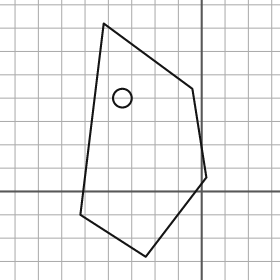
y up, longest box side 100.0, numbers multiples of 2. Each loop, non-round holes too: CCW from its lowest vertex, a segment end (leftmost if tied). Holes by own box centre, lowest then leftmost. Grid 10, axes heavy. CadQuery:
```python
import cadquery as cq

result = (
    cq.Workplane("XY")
    .moveTo(-24.0, -28.0)
    .lineTo(2.0, 6.0)
    .lineTo(-4.0, 44.0)
    .lineTo(-42.0, 72.0)
    .lineTo(-52.0, -10.0)
    .close()
    .moveTo(-34.0, 40.0)
    .circle(4.0)
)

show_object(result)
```